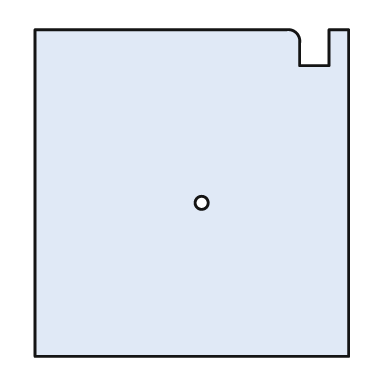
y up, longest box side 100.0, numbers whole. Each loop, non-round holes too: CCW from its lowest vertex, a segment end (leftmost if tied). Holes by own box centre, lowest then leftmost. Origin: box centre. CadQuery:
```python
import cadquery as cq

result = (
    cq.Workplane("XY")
    .moveTo(-48.0, -50.0)
    .lineTo(48.0, -50.0)
    .lineTo(48.0, 50.0)
    .lineTo(42.0, 50.0)
    .lineTo(42.0, 39.0)
    .lineTo(33.0, 39.0)
    .lineTo(33.0, 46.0)
    .threePointArc((32.0, 49.0), (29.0, 50.0))
    .lineTo(-48.0, 50.0)
    .close()
    .moveTo(3.0, -3.0)
    .circle(2.0)
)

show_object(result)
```